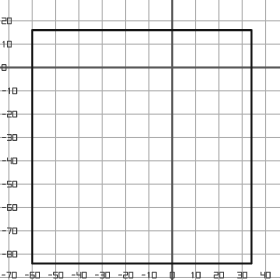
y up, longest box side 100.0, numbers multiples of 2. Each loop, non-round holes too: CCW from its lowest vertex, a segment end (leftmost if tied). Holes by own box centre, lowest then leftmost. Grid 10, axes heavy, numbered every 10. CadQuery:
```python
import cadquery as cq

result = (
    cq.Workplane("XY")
    .moveTo(-60.0, -84.0)
    .lineTo(34.0, -84.0)
    .lineTo(34.0, 16.0)
    .lineTo(-60.0, 16.0)
    .close()
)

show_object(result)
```